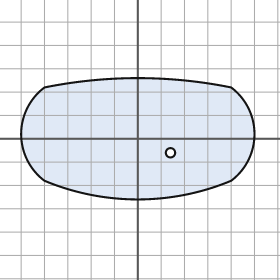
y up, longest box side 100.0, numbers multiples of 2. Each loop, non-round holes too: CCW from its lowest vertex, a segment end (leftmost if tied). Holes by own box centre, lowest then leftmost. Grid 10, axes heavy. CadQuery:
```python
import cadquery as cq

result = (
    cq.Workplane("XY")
    .moveTo(-40.0, -18.0)
    .threePointArc((0.0, -26.0), (40.0, -18.0))
    .threePointArc((50.0, 2.0), (40.0, 22.0))
    .threePointArc((0.0, 26.0), (-40.0, 22.0))
    .threePointArc((-50.0, 2.0), (-40.0, -18.0))
    .close()
    .moveTo(14.0, -6.0)
    .circle(2.0)
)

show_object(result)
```